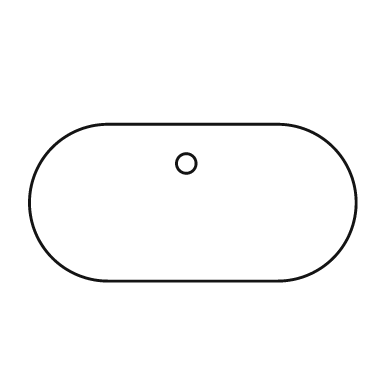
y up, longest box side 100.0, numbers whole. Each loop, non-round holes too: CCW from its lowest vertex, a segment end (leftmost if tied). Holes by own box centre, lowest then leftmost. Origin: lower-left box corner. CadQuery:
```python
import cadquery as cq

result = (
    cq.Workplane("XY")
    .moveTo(24.0, 0.0)
    .lineTo(76.0, 0.0)
    .threePointArc((100.0, 24.0), (76.0, 48.0))
    .lineTo(24.0, 48.0)
    .threePointArc((0.0, 24.0), (24.0, 0.0))
    .close()
    .moveTo(48.0, 36.0)
    .circle(3.0)
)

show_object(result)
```